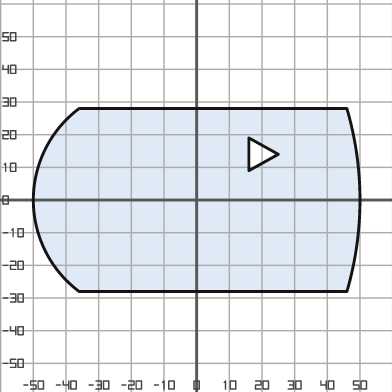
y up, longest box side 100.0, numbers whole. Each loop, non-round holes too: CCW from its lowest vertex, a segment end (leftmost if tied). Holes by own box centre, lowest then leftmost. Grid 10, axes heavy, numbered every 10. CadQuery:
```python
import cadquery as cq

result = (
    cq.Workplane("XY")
    .moveTo(-36.0, -28.0)
    .lineTo(46.0, -28.0)
    .threePointArc((50.0, 0.0), (46.0, 28.0))
    .lineTo(-36.0, 28.0)
    .threePointArc((-50.0, 0.0), (-36.0, -28.0))
    .close()
    .moveTo(16.0, 9.0)
    .lineTo(25.0, 14.0)
    .lineTo(16.0, 19.0)
    .close()
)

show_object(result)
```